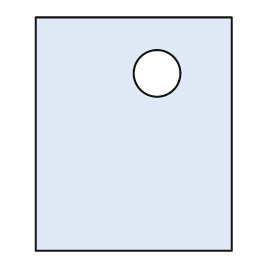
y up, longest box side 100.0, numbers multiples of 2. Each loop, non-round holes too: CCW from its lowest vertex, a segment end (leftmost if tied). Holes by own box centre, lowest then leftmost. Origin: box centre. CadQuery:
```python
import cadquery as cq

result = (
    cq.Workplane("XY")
    .moveTo(-42.0, -50.0)
    .lineTo(42.0, -50.0)
    .lineTo(42.0, 50.0)
    .lineTo(-42.0, 50.0)
    .close()
    .moveTo(10.0, 26.0)
    .circle(10.0)
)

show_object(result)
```